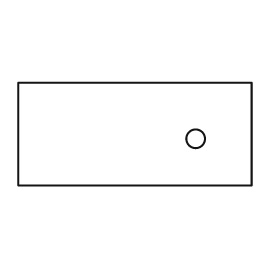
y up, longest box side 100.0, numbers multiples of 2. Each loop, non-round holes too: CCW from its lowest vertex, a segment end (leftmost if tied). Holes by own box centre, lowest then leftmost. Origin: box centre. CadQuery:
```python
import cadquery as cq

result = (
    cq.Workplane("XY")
    .moveTo(-50.0, -22.0)
    .lineTo(50.0, -22.0)
    .lineTo(50.0, 22.0)
    .lineTo(-50.0, 22.0)
    .close()
    .moveTo(26.0, -2.0)
    .circle(4.0)
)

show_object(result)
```